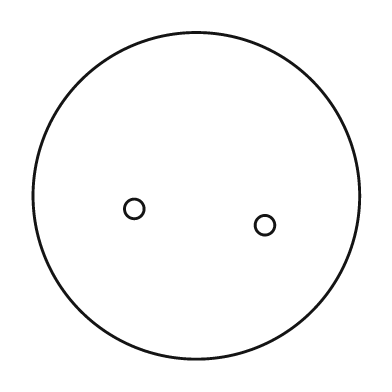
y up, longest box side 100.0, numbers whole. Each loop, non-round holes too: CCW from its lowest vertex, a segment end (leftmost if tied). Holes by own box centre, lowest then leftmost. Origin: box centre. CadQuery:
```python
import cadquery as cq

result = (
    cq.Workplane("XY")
    .moveTo(0.0, 0.0)
    .circle(50.0)
    .moveTo(21.0, -9.0)
    .circle(3.0)
    .moveTo(-19.0, -4.0)
    .circle(3.0)
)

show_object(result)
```